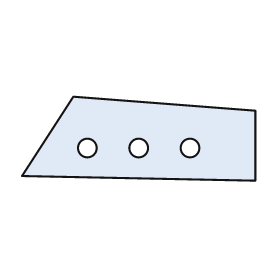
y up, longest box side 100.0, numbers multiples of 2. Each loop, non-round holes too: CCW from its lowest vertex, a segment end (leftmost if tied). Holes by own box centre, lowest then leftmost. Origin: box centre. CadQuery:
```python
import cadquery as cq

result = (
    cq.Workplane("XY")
    .moveTo(50.0, -18.0)
    .lineTo(50.0, 12.0)
    .lineTo(-28.0, 18.0)
    .lineTo(-50.0, -16.0)
    .close()
    .moveTo(-22.0, -4.0)
    .circle(4.0)
    .moveTo(0.0, -4.0)
    .circle(4.0)
    .moveTo(22.0, -4.0)
    .circle(4.0)
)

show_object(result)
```